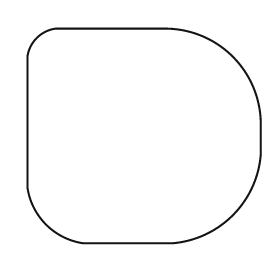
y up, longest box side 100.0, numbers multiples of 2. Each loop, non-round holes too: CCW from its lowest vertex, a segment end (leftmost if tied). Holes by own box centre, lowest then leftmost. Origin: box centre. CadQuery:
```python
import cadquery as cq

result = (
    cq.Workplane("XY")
    .moveTo(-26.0, -46.0)
    .lineTo(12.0, -46.0)
    .threePointArc((38.0, -34.0), (50.0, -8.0))
    .lineTo(50.0, 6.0)
    .threePointArc((38.0, 34.0), (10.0, 46.0))
    .lineTo(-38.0, 46.0)
    .threePointArc((-46.0, 42.0), (-50.0, 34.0))
    .lineTo(-50.0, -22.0)
    .threePointArc((-42.0, -38.0), (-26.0, -46.0))
    .close()
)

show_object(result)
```